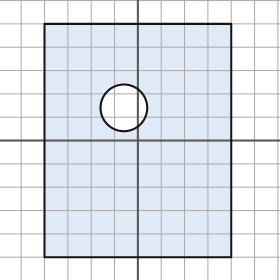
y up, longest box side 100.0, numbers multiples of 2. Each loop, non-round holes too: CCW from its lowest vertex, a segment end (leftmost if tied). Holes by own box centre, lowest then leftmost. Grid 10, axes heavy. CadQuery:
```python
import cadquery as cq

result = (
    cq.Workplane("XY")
    .moveTo(-40.0, -50.0)
    .lineTo(40.0, -50.0)
    .lineTo(40.0, 50.0)
    .lineTo(-40.0, 50.0)
    .close()
    .moveTo(-6.0, 14.0)
    .circle(10.0)
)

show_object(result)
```